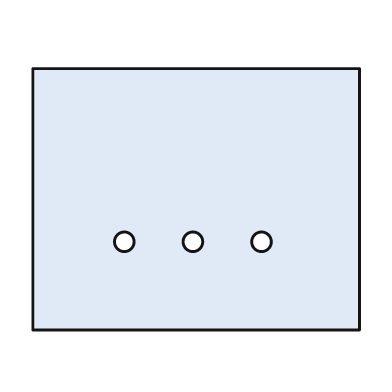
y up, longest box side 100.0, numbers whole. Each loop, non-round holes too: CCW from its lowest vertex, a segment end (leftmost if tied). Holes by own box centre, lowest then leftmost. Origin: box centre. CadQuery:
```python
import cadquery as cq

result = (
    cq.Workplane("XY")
    .moveTo(-50.0, -40.0)
    .lineTo(50.0, -40.0)
    .lineTo(50.0, 40.0)
    .lineTo(-50.0, 40.0)
    .close()
    .moveTo(-22.0, -13.0)
    .circle(3.0)
    .moveTo(-1.0, -13.0)
    .circle(3.0)
    .moveTo(20.0, -13.0)
    .circle(3.0)
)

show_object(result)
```